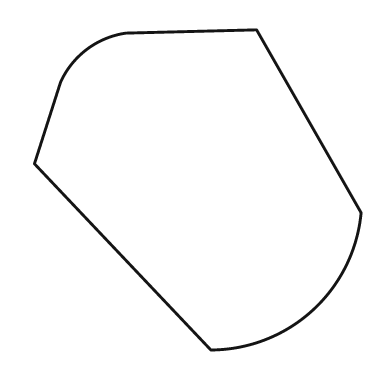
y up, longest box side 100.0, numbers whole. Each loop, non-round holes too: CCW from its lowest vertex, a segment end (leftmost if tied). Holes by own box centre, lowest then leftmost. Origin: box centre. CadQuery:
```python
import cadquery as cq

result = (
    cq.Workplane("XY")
    .moveTo(4.0, -49.0)
    .threePointArc((35.0, -37.0), (50.0, -7.0))
    .lineTo(18.0, 49.0)
    .lineTo(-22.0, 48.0)
    .threePointArc((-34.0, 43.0), (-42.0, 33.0))
    .lineTo(-50.0, 8.0)
    .close()
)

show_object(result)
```